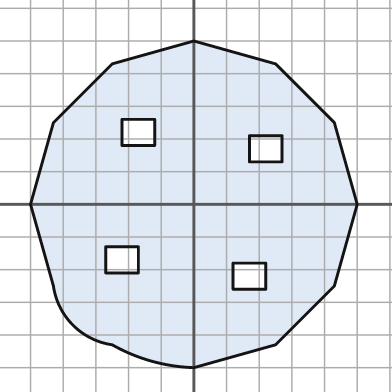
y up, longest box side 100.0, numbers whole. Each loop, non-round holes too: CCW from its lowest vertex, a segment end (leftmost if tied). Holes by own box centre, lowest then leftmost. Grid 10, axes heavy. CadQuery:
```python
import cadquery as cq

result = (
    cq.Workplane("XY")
    .moveTo(0.0, -50.0)
    .lineTo(25.0, -43.0)
    .lineTo(43.0, -25.0)
    .lineTo(50.0, 0.0)
    .lineTo(43.0, 25.0)
    .lineTo(25.0, 43.0)
    .lineTo(0.0, 50.0)
    .lineTo(-25.0, 43.0)
    .lineTo(-43.0, 25.0)
    .lineTo(-50.0, 0.0)
    .lineTo(-43.0, -25.0)
    .threePointArc((-37.0, -37.0), (-25.0, -43.0))
    .threePointArc((-13.0, -48.0), (0.0, -50.0))
    .close()
    .moveTo(12.0, -26.0)
    .lineTo(22.0, -26.0)
    .lineTo(22.0, -18.0)
    .lineTo(12.0, -18.0)
    .close()
    .moveTo(-27.0, -21.0)
    .lineTo(-17.0, -21.0)
    .lineTo(-17.0, -13.0)
    .lineTo(-27.0, -13.0)
    .close()
    .moveTo(17.0, 13.0)
    .lineTo(27.0, 13.0)
    .lineTo(27.0, 21.0)
    .lineTo(17.0, 21.0)
    .close()
    .moveTo(-22.0, 18.0)
    .lineTo(-12.0, 18.0)
    .lineTo(-12.0, 26.0)
    .lineTo(-22.0, 26.0)
    .close()
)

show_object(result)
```